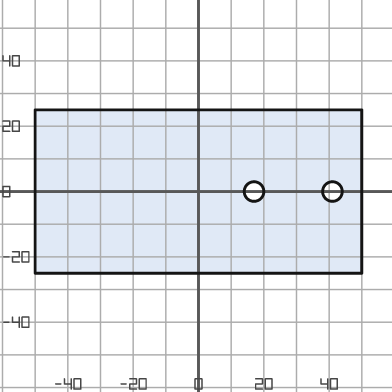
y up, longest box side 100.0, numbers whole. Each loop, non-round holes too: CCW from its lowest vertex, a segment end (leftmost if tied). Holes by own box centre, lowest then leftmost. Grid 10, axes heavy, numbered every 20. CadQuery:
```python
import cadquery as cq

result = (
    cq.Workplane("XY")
    .moveTo(-50.0, -25.0)
    .lineTo(50.0, -25.0)
    .lineTo(50.0, 25.0)
    .lineTo(-50.0, 25.0)
    .close()
    .moveTo(17.0, 0.0)
    .circle(3.0)
    .moveTo(41.0, 0.0)
    .circle(3.0)
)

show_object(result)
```